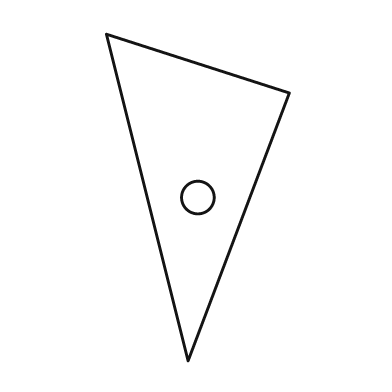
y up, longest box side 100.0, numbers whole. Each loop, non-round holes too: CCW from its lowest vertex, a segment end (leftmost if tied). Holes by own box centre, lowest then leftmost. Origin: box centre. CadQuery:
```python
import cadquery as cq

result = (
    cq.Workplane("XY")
    .moveTo(-3.0, -50.0)
    .lineTo(28.0, 32.0)
    .lineTo(-28.0, 50.0)
    .close()
    .moveTo(0.0, 0.0)
    .circle(5.0)
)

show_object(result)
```